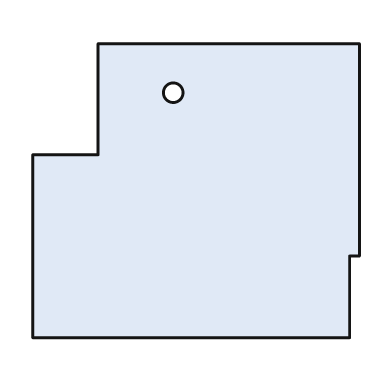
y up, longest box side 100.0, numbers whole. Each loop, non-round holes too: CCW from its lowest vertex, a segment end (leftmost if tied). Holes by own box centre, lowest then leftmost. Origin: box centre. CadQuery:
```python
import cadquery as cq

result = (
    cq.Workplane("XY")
    .moveTo(-50.0, -45.0)
    .lineTo(47.0, -45.0)
    .lineTo(47.0, -20.0)
    .lineTo(50.0, -20.0)
    .lineTo(50.0, 45.0)
    .lineTo(-30.0, 45.0)
    .lineTo(-30.0, 11.0)
    .lineTo(-50.0, 11.0)
    .close()
    .moveTo(-7.0, 30.0)
    .circle(3.0)
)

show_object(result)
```